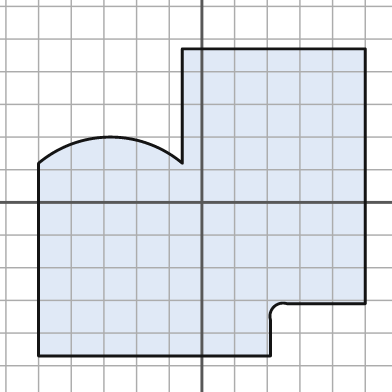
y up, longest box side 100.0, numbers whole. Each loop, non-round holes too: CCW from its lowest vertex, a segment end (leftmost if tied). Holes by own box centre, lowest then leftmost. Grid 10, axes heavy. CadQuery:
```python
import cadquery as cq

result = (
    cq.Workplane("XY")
    .moveTo(-50.0, -47.0)
    .lineTo(21.0, -47.0)
    .lineTo(21.0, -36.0)
    .threePointArc((22.0, -32.0), (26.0, -31.0))
    .lineTo(50.0, -31.0)
    .lineTo(50.0, 47.0)
    .lineTo(-6.0, 47.0)
    .lineTo(-6.0, 12.0)
    .threePointArc((-28.0, 20.0), (-50.0, 12.0))
    .close()
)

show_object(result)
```